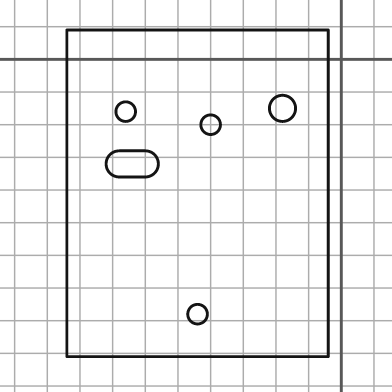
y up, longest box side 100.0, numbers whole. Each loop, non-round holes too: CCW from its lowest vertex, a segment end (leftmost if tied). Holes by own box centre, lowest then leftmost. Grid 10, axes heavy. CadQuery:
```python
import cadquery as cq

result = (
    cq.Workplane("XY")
    .moveTo(-84.0, -91.0)
    .lineTo(-4.0, -91.0)
    .lineTo(-4.0, 9.0)
    .lineTo(-84.0, 9.0)
    .close()
    .moveTo(-44.0, -78.0)
    .circle(3.0)
    .moveTo(-68.0, -36.0)
    .lineTo(-60.0, -36.0)
    .threePointArc((-56.0, -32.0), (-60.0, -28.0))
    .lineTo(-68.0, -28.0)
    .threePointArc((-72.0, -32.0), (-68.0, -36.0))
    .close()
    .moveTo(-40.0, -20.0)
    .circle(3.0)
    .moveTo(-66.0, -16.0)
    .circle(3.0)
    .moveTo(-18.0, -15.0)
    .circle(4.0)
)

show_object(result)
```